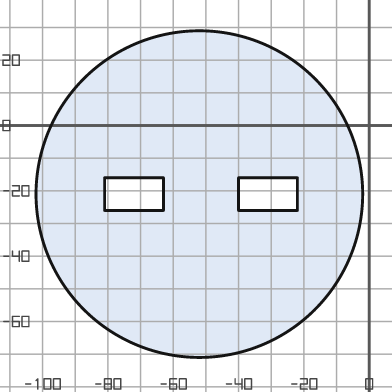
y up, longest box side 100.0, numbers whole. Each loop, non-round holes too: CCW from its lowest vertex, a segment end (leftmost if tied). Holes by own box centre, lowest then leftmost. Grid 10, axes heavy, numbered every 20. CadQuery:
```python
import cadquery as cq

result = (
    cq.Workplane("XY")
    .moveTo(-52.0, -21.0)
    .circle(50.0)
    .moveTo(-81.0, -26.0)
    .lineTo(-63.0, -26.0)
    .lineTo(-63.0, -16.0)
    .lineTo(-81.0, -16.0)
    .close()
    .moveTo(-40.0, -26.0)
    .lineTo(-22.0, -26.0)
    .lineTo(-22.0, -16.0)
    .lineTo(-40.0, -16.0)
    .close()
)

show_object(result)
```